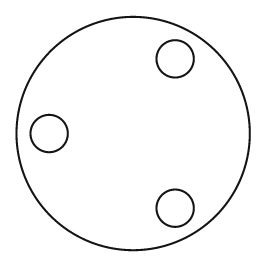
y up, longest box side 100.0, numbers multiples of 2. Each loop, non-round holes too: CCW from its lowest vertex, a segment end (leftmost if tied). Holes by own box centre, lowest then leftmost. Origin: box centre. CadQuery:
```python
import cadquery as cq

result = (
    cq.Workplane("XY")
    .moveTo(0.0, 0.0)
    .circle(50.0)
    .moveTo(18.0, -32.0)
    .circle(8.0)
    .moveTo(-36.0, 0.0)
    .circle(8.0)
    .moveTo(18.0, 32.0)
    .circle(8.0)
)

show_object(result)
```